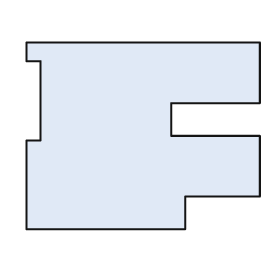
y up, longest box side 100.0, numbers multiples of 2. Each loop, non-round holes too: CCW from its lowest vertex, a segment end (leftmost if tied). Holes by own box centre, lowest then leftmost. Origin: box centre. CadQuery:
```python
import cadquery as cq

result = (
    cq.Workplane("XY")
    .moveTo(-50.0, -40.0)
    .lineTo(18.0, -40.0)
    .lineTo(18.0, -26.0)
    .lineTo(50.0, -26.0)
    .lineTo(50.0, 0.0)
    .lineTo(12.0, 0.0)
    .lineTo(12.0, 14.0)
    .lineTo(50.0, 14.0)
    .lineTo(50.0, 40.0)
    .lineTo(-50.0, 40.0)
    .lineTo(-50.0, 32.0)
    .lineTo(-44.0, 32.0)
    .lineTo(-44.0, -2.0)
    .lineTo(-50.0, -2.0)
    .close()
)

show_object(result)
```